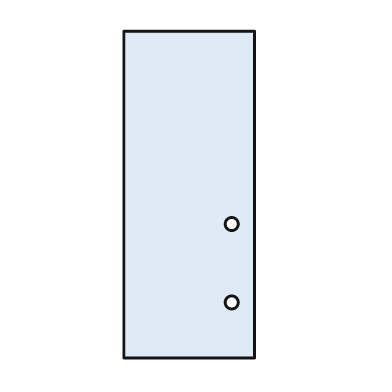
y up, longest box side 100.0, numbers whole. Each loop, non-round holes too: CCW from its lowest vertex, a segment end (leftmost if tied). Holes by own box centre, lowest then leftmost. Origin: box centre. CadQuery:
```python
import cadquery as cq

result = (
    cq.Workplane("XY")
    .moveTo(-20.0, -50.0)
    .lineTo(20.0, -50.0)
    .lineTo(20.0, 50.0)
    .lineTo(-20.0, 50.0)
    .close()
    .moveTo(13.0, -33.0)
    .circle(2.0)
    .moveTo(13.0, -9.0)
    .circle(2.0)
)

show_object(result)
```